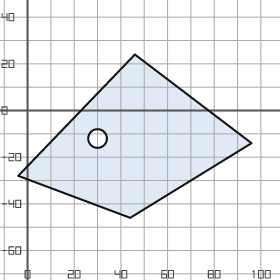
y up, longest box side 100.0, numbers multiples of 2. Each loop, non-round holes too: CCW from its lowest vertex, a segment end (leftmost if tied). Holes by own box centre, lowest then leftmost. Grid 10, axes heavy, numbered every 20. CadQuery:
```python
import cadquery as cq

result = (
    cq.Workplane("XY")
    .moveTo(44.0, -46.0)
    .lineTo(96.0, -14.0)
    .lineTo(46.0, 24.0)
    .lineTo(-4.0, -28.0)
    .close()
    .moveTo(30.0, -12.0)
    .circle(4.0)
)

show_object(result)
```